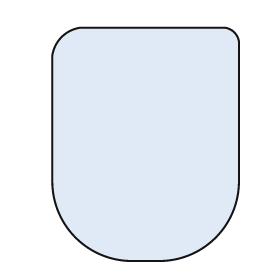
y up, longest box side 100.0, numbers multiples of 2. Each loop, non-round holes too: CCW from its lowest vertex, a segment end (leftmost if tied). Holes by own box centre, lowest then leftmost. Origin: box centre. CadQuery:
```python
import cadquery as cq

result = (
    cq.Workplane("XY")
    .moveTo(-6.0, -50.0)
    .lineTo(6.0, -50.0)
    .threePointArc((30.0, -40.0), (40.0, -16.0))
    .lineTo(40.0, 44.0)
    .threePointArc((38.0, 48.0), (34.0, 50.0))
    .lineTo(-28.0, 50.0)
    .threePointArc((-36.0, 46.0), (-40.0, 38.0))
    .lineTo(-40.0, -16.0)
    .threePointArc((-30.0, -40.0), (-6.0, -50.0))
    .close()
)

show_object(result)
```